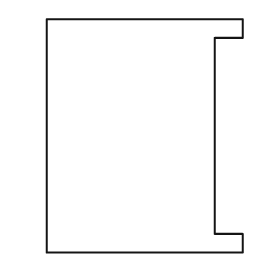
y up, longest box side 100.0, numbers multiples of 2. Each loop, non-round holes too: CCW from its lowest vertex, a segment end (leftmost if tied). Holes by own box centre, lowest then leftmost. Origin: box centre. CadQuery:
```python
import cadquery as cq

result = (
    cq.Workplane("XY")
    .moveTo(-42.0, -50.0)
    .lineTo(42.0, -50.0)
    .lineTo(42.0, -42.0)
    .lineTo(30.0, -42.0)
    .lineTo(30.0, 42.0)
    .lineTo(42.0, 42.0)
    .lineTo(42.0, 50.0)
    .lineTo(-42.0, 50.0)
    .close()
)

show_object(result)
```